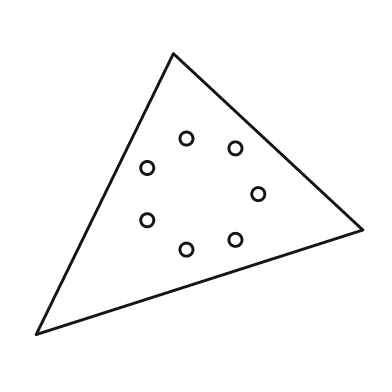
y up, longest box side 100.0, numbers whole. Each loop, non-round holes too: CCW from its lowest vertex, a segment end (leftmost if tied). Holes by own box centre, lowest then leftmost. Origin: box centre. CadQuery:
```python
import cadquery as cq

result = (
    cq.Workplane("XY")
    .moveTo(-50.0, -43.0)
    .lineTo(50.0, -11.0)
    .lineTo(-8.0, 43.0)
    .close()
    .moveTo(-4.0, -17.0)
    .circle(2.0)
    .moveTo(11.0, -14.0)
    .circle(2.0)
    .moveTo(-16.0, -8.0)
    .circle(2.0)
    .moveTo(18.0, 0.0)
    .circle(2.0)
    .moveTo(-16.0, 8.0)
    .circle(2.0)
    .moveTo(11.0, 14.0)
    .circle(2.0)
    .moveTo(-4.0, 17.0)
    .circle(2.0)
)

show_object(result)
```